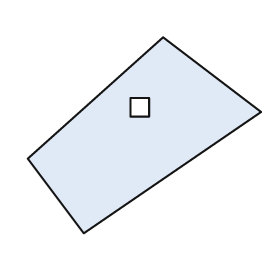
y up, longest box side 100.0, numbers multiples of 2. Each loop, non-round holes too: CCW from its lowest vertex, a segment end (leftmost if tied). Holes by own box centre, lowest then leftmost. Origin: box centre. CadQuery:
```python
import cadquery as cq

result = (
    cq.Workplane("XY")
    .moveTo(-26.0, -42.0)
    .lineTo(50.0, 10.0)
    .lineTo(8.0, 42.0)
    .lineTo(-50.0, -10.0)
    .close()
    .moveTo(-6.0, 8.0)
    .lineTo(2.0, 8.0)
    .lineTo(2.0, 16.0)
    .lineTo(-6.0, 16.0)
    .close()
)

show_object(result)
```